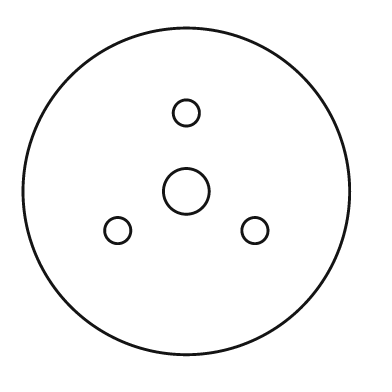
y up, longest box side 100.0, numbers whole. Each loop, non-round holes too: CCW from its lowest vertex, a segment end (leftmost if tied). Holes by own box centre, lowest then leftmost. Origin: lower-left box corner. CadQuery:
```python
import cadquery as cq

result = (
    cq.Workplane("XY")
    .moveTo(50.0, 50.0)
    .circle(50.0)
    .moveTo(29.0, 38.0)
    .circle(4.0)
    .moveTo(71.0, 38.0)
    .circle(4.0)
    .moveTo(50.0, 50.0)
    .circle(7.0)
    .moveTo(50.0, 74.0)
    .circle(4.0)
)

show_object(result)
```